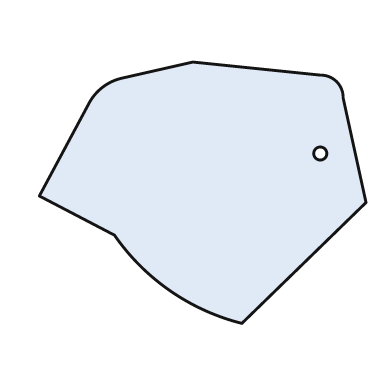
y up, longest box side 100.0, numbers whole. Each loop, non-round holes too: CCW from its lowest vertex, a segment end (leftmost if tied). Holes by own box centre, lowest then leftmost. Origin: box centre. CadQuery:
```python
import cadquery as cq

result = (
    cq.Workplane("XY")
    .moveTo(12.0, -40.0)
    .lineTo(50.0, -3.0)
    .lineTo(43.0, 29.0)
    .threePointArc((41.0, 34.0), (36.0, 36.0))
    .lineTo(-3.0, 40.0)
    .lineTo(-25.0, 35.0)
    .threePointArc((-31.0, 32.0), (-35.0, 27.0))
    .lineTo(-50.0, -1.0)
    .lineTo(-27.0, -13.0)
    .threePointArc((-10.0, -30.0), (12.0, -40.0))
    .close()
    .moveTo(36.0, 12.0)
    .circle(2.0)
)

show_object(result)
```